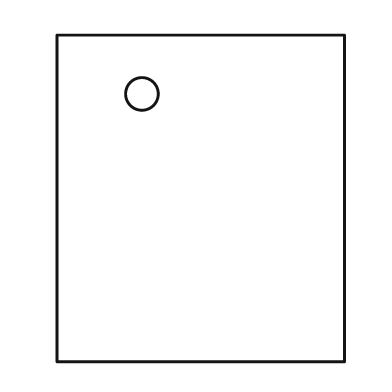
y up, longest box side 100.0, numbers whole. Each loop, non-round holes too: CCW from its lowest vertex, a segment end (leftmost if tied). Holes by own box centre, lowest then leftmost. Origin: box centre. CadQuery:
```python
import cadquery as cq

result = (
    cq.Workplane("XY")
    .moveTo(-44.0, -50.0)
    .lineTo(44.0, -50.0)
    .lineTo(44.0, 50.0)
    .lineTo(-44.0, 50.0)
    .close()
    .moveTo(-18.0, 32.0)
    .circle(5.0)
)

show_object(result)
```